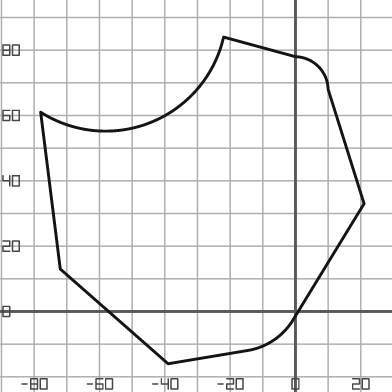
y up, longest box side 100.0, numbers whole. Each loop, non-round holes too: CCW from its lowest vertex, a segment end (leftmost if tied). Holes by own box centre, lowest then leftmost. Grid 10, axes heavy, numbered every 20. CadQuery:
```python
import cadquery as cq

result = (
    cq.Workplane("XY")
    .moveTo(-39.0, -16.0)
    .lineTo(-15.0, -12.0)
    .threePointArc((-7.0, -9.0), (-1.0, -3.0))
    .lineTo(21.0, 33.0)
    .lineTo(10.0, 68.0)
    .threePointArc((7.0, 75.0), (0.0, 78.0))
    .lineTo(-22.0, 84.0)
    .threePointArc((-44.0, 58.0), (-78.0, 61.0))
    .lineTo(-72.0, 13.0)
    .close()
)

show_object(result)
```